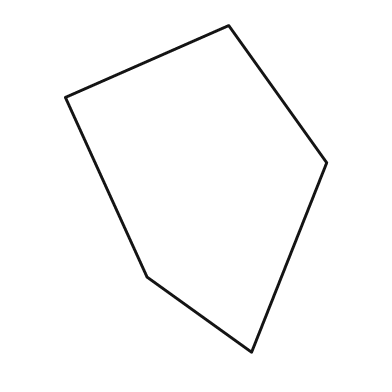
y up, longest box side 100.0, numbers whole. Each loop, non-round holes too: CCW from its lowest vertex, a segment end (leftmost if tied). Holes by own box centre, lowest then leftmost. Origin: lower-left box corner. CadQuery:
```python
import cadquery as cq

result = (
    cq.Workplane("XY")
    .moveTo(57.0, 0.0)
    .lineTo(80.0, 58.0)
    .lineTo(50.0, 100.0)
    .lineTo(0.0, 78.0)
    .lineTo(25.0, 23.0)
    .close()
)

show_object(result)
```